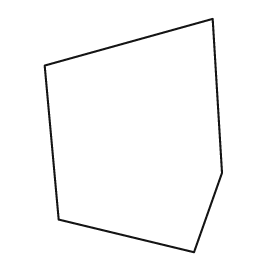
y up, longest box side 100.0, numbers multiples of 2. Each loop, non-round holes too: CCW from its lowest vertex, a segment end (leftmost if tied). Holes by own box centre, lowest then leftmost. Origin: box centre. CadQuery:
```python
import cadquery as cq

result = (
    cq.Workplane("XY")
    .moveTo(26.0, -50.0)
    .lineTo(38.0, -16.0)
    .lineTo(34.0, 50.0)
    .lineTo(-38.0, 30.0)
    .lineTo(-32.0, -36.0)
    .close()
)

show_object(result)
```